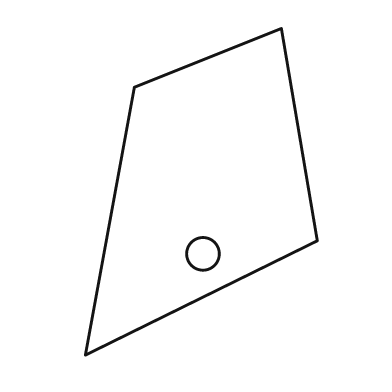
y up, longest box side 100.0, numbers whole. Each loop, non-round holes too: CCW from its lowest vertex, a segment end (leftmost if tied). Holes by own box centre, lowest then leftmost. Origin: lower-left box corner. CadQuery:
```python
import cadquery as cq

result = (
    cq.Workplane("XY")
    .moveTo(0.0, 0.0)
    .lineTo(71.0, 35.0)
    .lineTo(60.0, 100.0)
    .lineTo(15.0, 82.0)
    .close()
    .moveTo(36.0, 31.0)
    .circle(5.0)
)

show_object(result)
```